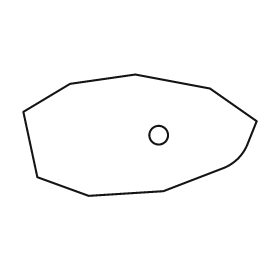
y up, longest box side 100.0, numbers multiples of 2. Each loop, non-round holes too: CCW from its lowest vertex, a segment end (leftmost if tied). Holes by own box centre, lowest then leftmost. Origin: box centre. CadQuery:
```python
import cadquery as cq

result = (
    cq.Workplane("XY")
    .moveTo(-22.0, -26.0)
    .lineTo(10.0, -24.0)
    .lineTo(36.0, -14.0)
    .threePointArc((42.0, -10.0), (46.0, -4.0))
    .lineTo(50.0, 6.0)
    .lineTo(30.0, 20.0)
    .lineTo(-2.0, 26.0)
    .lineTo(-30.0, 22.0)
    .lineTo(-50.0, 10.0)
    .lineTo(-44.0, -18.0)
    .close()
    .moveTo(8.0, 0.0)
    .circle(4.0)
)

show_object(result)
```